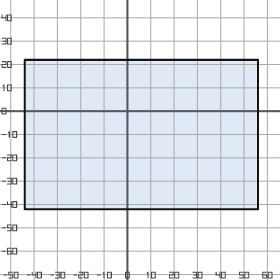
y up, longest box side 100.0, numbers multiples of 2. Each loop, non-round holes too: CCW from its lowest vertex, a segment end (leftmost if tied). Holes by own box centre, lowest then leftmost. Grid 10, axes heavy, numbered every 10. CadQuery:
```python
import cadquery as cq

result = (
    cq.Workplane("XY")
    .moveTo(-44.0, -42.0)
    .lineTo(56.0, -42.0)
    .lineTo(56.0, 22.0)
    .lineTo(-44.0, 22.0)
    .close()
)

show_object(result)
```